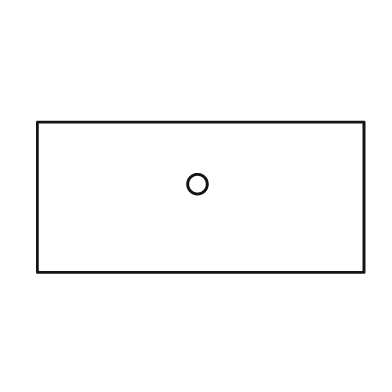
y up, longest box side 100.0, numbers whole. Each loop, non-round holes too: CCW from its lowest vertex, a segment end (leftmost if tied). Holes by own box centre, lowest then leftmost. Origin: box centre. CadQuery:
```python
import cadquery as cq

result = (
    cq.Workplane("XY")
    .moveTo(-50.0, -23.0)
    .lineTo(50.0, -23.0)
    .lineTo(50.0, 23.0)
    .lineTo(-50.0, 23.0)
    .close()
    .moveTo(-1.0, 4.0)
    .circle(3.0)
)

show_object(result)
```